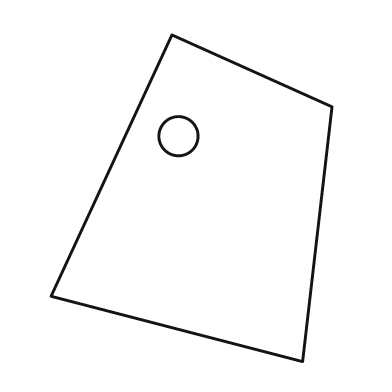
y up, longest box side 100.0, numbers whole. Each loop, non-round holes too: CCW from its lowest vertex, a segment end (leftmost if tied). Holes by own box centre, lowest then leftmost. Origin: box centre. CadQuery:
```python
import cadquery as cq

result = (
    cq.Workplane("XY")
    .moveTo(34.0, -50.0)
    .lineTo(43.0, 28.0)
    .lineTo(-6.0, 50.0)
    .lineTo(-43.0, -30.0)
    .close()
    .moveTo(-4.0, 19.0)
    .circle(6.0)
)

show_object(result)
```